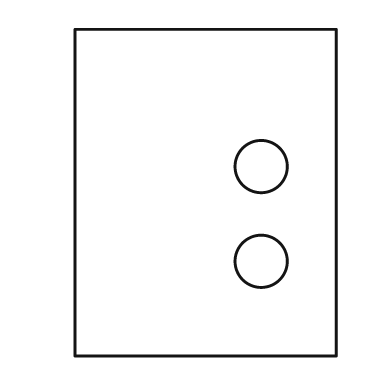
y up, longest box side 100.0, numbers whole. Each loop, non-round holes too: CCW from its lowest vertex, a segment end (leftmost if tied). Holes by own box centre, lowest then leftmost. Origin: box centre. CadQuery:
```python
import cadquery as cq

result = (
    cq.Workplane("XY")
    .moveTo(-40.0, -50.0)
    .lineTo(40.0, -50.0)
    .lineTo(40.0, 50.0)
    .lineTo(-40.0, 50.0)
    .close()
    .moveTo(17.0, -21.0)
    .circle(8.0)
    .moveTo(17.0, 8.0)
    .circle(8.0)
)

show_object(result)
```